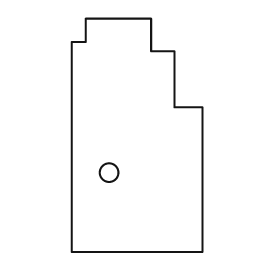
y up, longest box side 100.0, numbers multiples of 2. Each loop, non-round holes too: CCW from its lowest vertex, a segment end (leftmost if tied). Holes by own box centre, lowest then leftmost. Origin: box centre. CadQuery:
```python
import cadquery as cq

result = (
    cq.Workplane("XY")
    .moveTo(-28.0, -50.0)
    .lineTo(28.0, -50.0)
    .lineTo(28.0, 12.0)
    .lineTo(16.0, 12.0)
    .lineTo(16.0, 36.0)
    .lineTo(6.0, 36.0)
    .lineTo(6.0, 50.0)
    .lineTo(-22.0, 50.0)
    .lineTo(-22.0, 40.0)
    .lineTo(-28.0, 40.0)
    .close()
    .moveTo(-12.0, -16.0)
    .circle(4.0)
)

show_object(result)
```